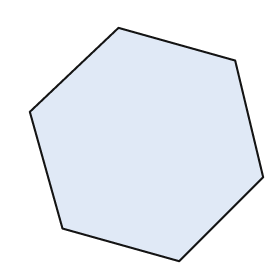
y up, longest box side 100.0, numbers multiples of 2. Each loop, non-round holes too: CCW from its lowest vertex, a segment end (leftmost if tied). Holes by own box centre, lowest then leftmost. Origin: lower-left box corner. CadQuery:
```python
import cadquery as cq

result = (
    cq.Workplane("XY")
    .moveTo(64.0, 0.0)
    .lineTo(100.0, 36.0)
    .lineTo(88.0, 86.0)
    .lineTo(38.0, 100.0)
    .lineTo(0.0, 64.0)
    .lineTo(14.0, 14.0)
    .close()
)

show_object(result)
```